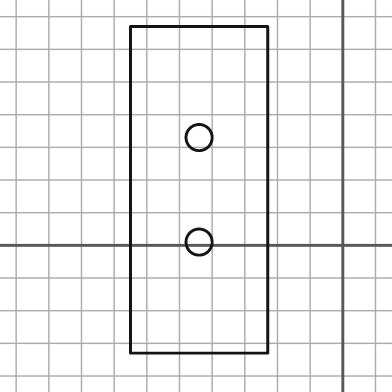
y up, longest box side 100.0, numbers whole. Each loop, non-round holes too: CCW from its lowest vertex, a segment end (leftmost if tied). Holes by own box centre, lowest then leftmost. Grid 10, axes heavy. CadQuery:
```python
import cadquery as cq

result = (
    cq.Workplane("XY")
    .moveTo(-65.0, -33.0)
    .lineTo(-23.0, -33.0)
    .lineTo(-23.0, 67.0)
    .lineTo(-65.0, 67.0)
    .close()
    .moveTo(-44.0, 1.0)
    .circle(4.0)
    .moveTo(-44.0, 33.0)
    .circle(4.0)
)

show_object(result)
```